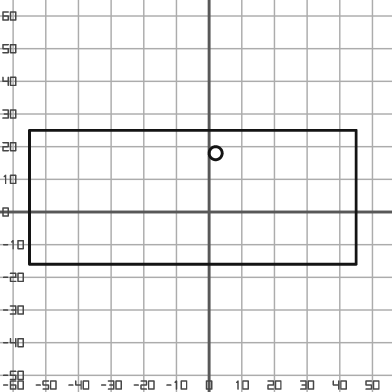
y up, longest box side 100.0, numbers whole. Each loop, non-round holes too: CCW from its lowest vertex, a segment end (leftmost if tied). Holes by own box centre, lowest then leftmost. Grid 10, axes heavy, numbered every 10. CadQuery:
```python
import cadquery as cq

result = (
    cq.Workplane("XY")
    .moveTo(-55.0, -16.0)
    .lineTo(45.0, -16.0)
    .lineTo(45.0, 25.0)
    .lineTo(-55.0, 25.0)
    .close()
    .moveTo(2.0, 18.0)
    .circle(2.0)
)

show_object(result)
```